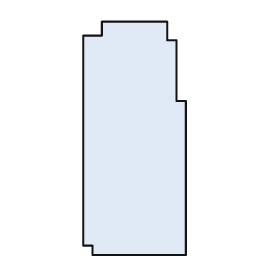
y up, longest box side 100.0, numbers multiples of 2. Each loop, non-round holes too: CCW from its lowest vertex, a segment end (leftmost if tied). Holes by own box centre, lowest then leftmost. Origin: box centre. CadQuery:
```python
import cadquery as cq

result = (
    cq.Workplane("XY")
    .moveTo(-18.0, -50.0)
    .lineTo(22.0, -50.0)
    .lineTo(22.0, 16.0)
    .lineTo(18.0, 16.0)
    .lineTo(18.0, 42.0)
    .lineTo(14.0, 42.0)
    .lineTo(14.0, 50.0)
    .lineTo(-14.0, 50.0)
    .lineTo(-14.0, 44.0)
    .lineTo(-22.0, 44.0)
    .lineTo(-22.0, -46.0)
    .lineTo(-18.0, -46.0)
    .close()
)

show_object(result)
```